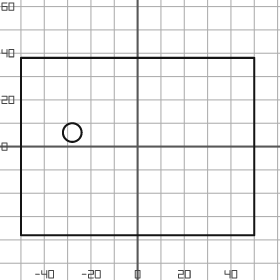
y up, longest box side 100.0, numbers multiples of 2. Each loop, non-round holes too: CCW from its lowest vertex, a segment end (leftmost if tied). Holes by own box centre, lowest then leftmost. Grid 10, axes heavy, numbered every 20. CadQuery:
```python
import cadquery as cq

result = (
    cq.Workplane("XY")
    .moveTo(-50.0, -38.0)
    .lineTo(50.0, -38.0)
    .lineTo(50.0, 38.0)
    .lineTo(-50.0, 38.0)
    .close()
    .moveTo(-28.0, 6.0)
    .circle(4.0)
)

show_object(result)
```